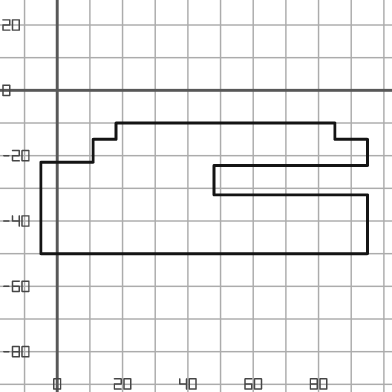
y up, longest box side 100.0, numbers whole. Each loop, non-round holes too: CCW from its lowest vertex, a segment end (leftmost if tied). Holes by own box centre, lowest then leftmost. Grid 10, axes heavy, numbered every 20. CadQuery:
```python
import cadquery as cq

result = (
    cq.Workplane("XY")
    .moveTo(-5.0, -50.0)
    .lineTo(95.0, -50.0)
    .lineTo(95.0, -32.0)
    .lineTo(48.0, -32.0)
    .lineTo(48.0, -23.0)
    .lineTo(95.0, -23.0)
    .lineTo(95.0, -15.0)
    .lineTo(85.0, -15.0)
    .lineTo(85.0, -10.0)
    .lineTo(18.0, -10.0)
    .lineTo(18.0, -15.0)
    .lineTo(11.0, -15.0)
    .lineTo(11.0, -22.0)
    .lineTo(-5.0, -22.0)
    .close()
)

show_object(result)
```